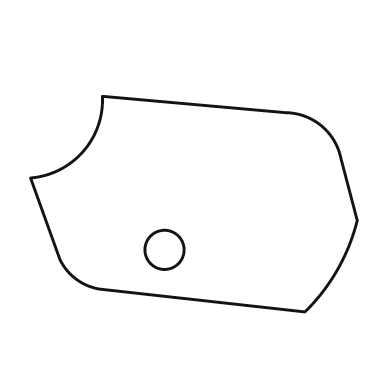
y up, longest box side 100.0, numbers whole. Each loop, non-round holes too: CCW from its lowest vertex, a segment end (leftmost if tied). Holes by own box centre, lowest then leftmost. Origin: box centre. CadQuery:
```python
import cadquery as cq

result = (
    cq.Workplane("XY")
    .moveTo(34.0, -33.0)
    .threePointArc((44.0, -20.0), (50.0, -5.0))
    .lineTo(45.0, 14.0)
    .threePointArc((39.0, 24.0), (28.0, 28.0))
    .lineTo(-28.0, 33.0)
    .threePointArc((-34.0, 16.0), (-50.0, 8.0))
    .lineTo(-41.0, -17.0)
    .threePointArc((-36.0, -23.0), (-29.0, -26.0))
    .close()
    .moveTo(-9.0, -14.0)
    .circle(6.0)
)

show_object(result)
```